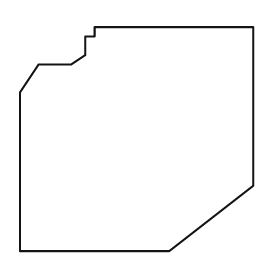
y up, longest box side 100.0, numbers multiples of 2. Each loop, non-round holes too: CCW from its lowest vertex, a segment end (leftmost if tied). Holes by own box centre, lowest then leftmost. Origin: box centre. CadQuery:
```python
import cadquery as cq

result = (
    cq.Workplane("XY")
    .moveTo(-50.0, -48.0)
    .lineTo(14.0, -48.0)
    .lineTo(50.0, -20.0)
    .lineTo(50.0, 48.0)
    .lineTo(-18.0, 48.0)
    .lineTo(-18.0, 44.0)
    .lineTo(-22.0, 44.0)
    .lineTo(-22.0, 36.0)
    .lineTo(-28.0, 32.0)
    .lineTo(-42.0, 32.0)
    .lineTo(-50.0, 20.0)
    .close()
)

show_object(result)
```